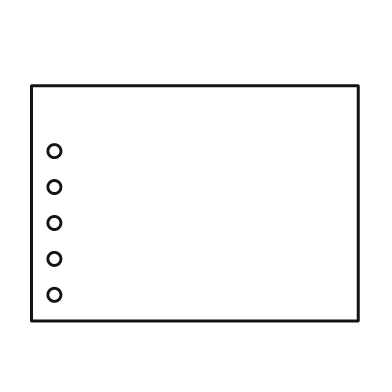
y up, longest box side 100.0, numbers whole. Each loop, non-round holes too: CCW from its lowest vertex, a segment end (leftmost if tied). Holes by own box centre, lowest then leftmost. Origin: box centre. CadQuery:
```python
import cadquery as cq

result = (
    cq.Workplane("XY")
    .moveTo(-50.0, -36.0)
    .lineTo(50.0, -36.0)
    .lineTo(50.0, 36.0)
    .lineTo(-50.0, 36.0)
    .close()
    .moveTo(-43.0, -28.0)
    .circle(2.0)
    .moveTo(-43.0, -17.0)
    .circle(2.0)
    .moveTo(-43.0, -6.0)
    .circle(2.0)
    .moveTo(-43.0, 5.0)
    .circle(2.0)
    .moveTo(-43.0, 16.0)
    .circle(2.0)
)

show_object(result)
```